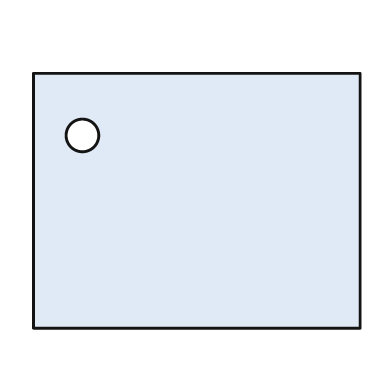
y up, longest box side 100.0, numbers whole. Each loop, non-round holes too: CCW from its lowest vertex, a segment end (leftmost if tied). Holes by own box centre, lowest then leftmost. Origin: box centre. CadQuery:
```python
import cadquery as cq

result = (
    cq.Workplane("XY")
    .moveTo(-50.0, -39.0)
    .lineTo(50.0, -39.0)
    .lineTo(50.0, 39.0)
    .lineTo(-50.0, 39.0)
    .close()
    .moveTo(-35.0, 20.0)
    .circle(5.0)
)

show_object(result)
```